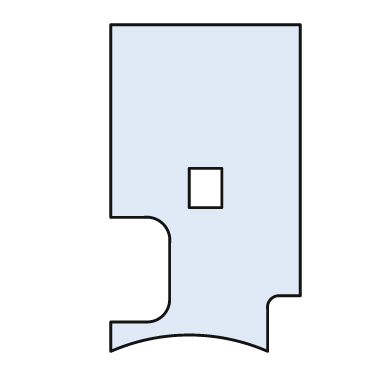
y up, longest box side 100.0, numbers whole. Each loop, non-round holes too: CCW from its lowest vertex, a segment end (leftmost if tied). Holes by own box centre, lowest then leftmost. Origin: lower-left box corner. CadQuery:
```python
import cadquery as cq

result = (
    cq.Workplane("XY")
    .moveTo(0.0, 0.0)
    .threePointArc((24.0, 5.0), (48.0, 0.0))
    .lineTo(48.0, 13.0)
    .threePointArc((49.0, 16.0), (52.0, 17.0))
    .lineTo(58.0, 17.0)
    .lineTo(58.0, 100.0)
    .lineTo(0.0, 100.0)
    .lineTo(0.0, 41.0)
    .lineTo(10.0, 41.0)
    .threePointArc((16.0, 39.0), (18.0, 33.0))
    .lineTo(18.0, 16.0)
    .threePointArc((16.0, 11.0), (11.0, 9.0))
    .lineTo(0.0, 9.0)
    .close()
    .moveTo(24.0, 44.0)
    .lineTo(34.0, 44.0)
    .lineTo(34.0, 56.0)
    .lineTo(24.0, 56.0)
    .close()
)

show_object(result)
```